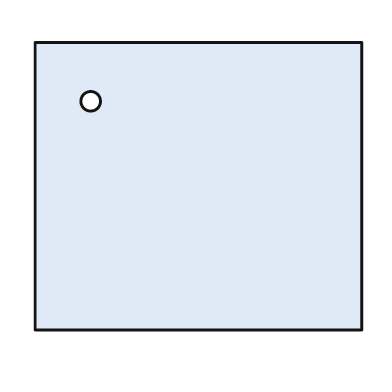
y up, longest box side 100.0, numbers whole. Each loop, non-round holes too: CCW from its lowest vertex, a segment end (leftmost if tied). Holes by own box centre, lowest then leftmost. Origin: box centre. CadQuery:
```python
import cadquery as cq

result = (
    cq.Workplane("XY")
    .moveTo(-50.0, -44.0)
    .lineTo(50.0, -44.0)
    .lineTo(50.0, 44.0)
    .lineTo(-50.0, 44.0)
    .close()
    .moveTo(-33.0, 26.0)
    .circle(3.0)
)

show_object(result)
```